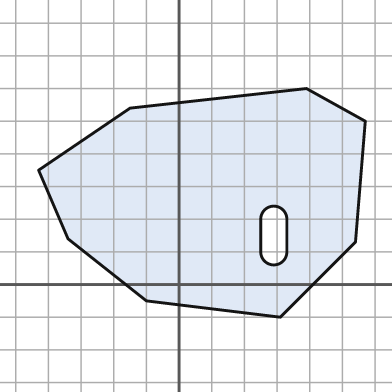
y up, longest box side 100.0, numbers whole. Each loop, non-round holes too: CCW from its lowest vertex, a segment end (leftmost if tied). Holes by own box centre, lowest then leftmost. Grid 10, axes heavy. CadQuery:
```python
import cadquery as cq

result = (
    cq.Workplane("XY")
    .moveTo(31.0, -10.0)
    .lineTo(54.0, 13.0)
    .lineTo(57.0, 50.0)
    .lineTo(39.0, 60.0)
    .lineTo(-15.0, 54.0)
    .lineTo(-43.0, 35.0)
    .lineTo(-34.0, 14.0)
    .lineTo(-10.0, -5.0)
    .close()
    .moveTo(25.0, 10.0)
    .threePointArc((29.0, 6.0), (33.0, 10.0))
    .lineTo(33.0, 20.0)
    .threePointArc((29.0, 24.0), (25.0, 20.0))
    .close()
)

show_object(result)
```